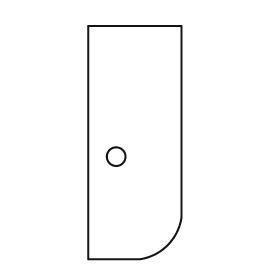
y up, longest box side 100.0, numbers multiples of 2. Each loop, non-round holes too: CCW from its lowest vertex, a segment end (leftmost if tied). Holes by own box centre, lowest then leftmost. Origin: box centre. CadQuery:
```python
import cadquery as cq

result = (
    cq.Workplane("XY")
    .moveTo(-20.0, -50.0)
    .lineTo(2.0, -50.0)
    .threePointArc((14.0, -44.0), (20.0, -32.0))
    .lineTo(20.0, 50.0)
    .lineTo(-20.0, 50.0)
    .close()
    .moveTo(-8.0, -6.0)
    .circle(4.0)
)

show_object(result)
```